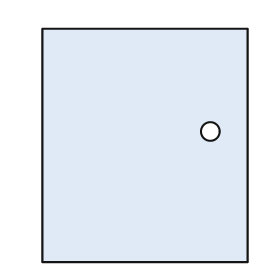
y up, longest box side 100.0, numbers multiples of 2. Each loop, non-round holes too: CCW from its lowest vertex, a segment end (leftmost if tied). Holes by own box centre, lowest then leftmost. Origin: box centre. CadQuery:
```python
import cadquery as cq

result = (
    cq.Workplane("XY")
    .moveTo(-44.0, -50.0)
    .lineTo(44.0, -50.0)
    .lineTo(44.0, 50.0)
    .lineTo(-44.0, 50.0)
    .close()
    .moveTo(28.0, 6.0)
    .circle(4.0)
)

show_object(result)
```